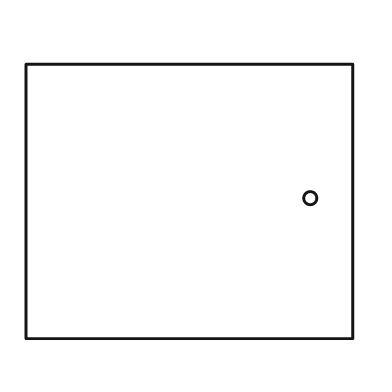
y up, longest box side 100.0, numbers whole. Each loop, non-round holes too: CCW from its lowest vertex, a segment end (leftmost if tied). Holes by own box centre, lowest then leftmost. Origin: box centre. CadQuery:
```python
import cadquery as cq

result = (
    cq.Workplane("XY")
    .moveTo(-50.0, -42.0)
    .lineTo(50.0, -42.0)
    .lineTo(50.0, 42.0)
    .lineTo(-50.0, 42.0)
    .close()
    .moveTo(37.0, 1.0)
    .circle(2.0)
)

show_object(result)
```